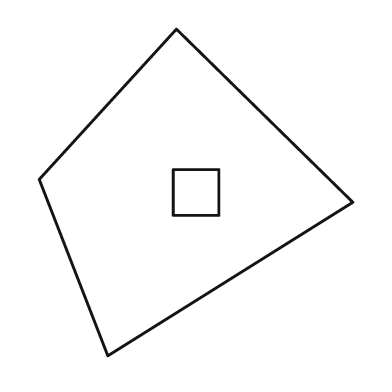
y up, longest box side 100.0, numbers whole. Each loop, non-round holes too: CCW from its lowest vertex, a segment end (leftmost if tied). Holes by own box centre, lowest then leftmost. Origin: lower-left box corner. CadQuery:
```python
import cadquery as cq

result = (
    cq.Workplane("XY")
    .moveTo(21.0, 0.0)
    .lineTo(96.0, 47.0)
    .lineTo(42.0, 100.0)
    .lineTo(0.0, 54.0)
    .close()
    .moveTo(41.0, 43.0)
    .lineTo(55.0, 43.0)
    .lineTo(55.0, 57.0)
    .lineTo(41.0, 57.0)
    .close()
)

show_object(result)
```